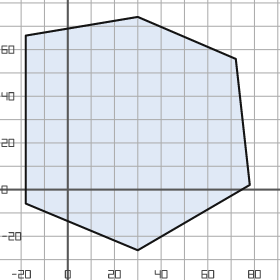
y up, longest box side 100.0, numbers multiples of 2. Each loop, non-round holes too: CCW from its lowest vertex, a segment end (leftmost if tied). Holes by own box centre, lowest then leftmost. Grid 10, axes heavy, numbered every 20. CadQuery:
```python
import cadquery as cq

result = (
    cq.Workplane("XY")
    .moveTo(30.0, -26.0)
    .lineTo(78.0, 2.0)
    .lineTo(72.0, 56.0)
    .lineTo(30.0, 74.0)
    .lineTo(-18.0, 66.0)
    .lineTo(-18.0, -6.0)
    .close()
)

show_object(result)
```